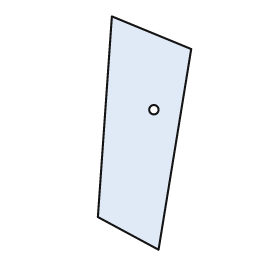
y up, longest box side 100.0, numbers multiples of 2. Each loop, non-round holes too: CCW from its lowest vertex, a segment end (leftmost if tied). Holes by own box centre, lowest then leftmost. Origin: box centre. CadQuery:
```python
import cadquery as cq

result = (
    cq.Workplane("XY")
    .moveTo(6.0, -50.0)
    .lineTo(20.0, 36.0)
    .lineTo(-14.0, 50.0)
    .lineTo(-20.0, -36.0)
    .close()
    .moveTo(4.0, 10.0)
    .circle(2.0)
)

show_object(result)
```